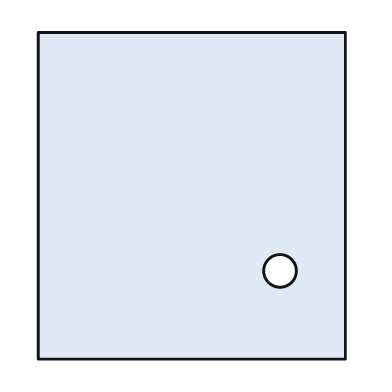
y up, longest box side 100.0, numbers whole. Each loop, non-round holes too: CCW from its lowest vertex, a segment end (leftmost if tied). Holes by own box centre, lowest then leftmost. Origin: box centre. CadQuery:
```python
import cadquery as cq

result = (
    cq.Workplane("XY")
    .moveTo(-47.0, -50.0)
    .lineTo(47.0, -50.0)
    .lineTo(47.0, 50.0)
    .lineTo(-47.0, 50.0)
    .close()
    .moveTo(27.0, -23.0)
    .circle(5.0)
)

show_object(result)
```